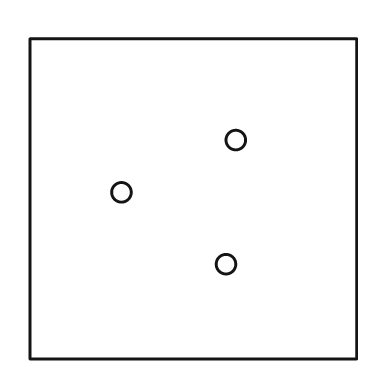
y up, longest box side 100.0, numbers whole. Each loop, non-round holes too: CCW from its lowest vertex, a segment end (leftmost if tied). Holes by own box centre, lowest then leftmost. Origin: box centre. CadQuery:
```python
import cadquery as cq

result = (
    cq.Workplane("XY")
    .moveTo(-50.0, -49.0)
    .lineTo(50.0, -49.0)
    .lineTo(50.0, 49.0)
    .lineTo(-50.0, 49.0)
    .close()
    .moveTo(10.0, -20.0)
    .circle(3.0)
    .moveTo(-22.0, 2.0)
    .circle(3.0)
    .moveTo(13.0, 18.0)
    .circle(3.0)
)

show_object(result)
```